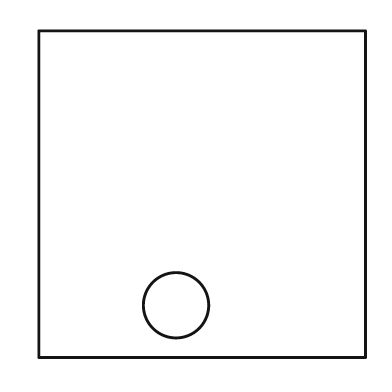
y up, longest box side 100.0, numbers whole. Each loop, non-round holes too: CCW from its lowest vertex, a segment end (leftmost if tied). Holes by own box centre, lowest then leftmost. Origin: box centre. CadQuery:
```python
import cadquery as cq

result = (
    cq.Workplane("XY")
    .moveTo(-50.0, -50.0)
    .lineTo(50.0, -50.0)
    .lineTo(50.0, 50.0)
    .lineTo(-50.0, 50.0)
    .close()
    .moveTo(-8.0, -34.0)
    .circle(10.0)
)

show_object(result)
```